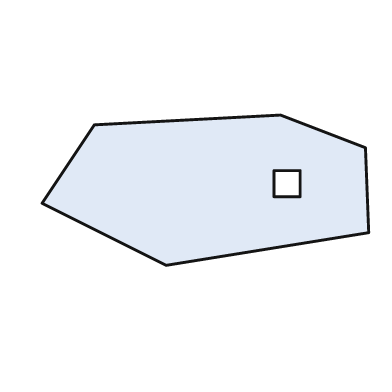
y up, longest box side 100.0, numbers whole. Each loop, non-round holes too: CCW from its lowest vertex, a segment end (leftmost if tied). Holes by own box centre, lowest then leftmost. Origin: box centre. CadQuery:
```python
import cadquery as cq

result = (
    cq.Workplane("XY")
    .moveTo(-12.0, -23.0)
    .lineTo(50.0, -13.0)
    .lineTo(49.0, 13.0)
    .lineTo(23.0, 23.0)
    .lineTo(-34.0, 20.0)
    .lineTo(-50.0, -4.0)
    .close()
    .moveTo(21.0, -2.0)
    .lineTo(29.0, -2.0)
    .lineTo(29.0, 6.0)
    .lineTo(21.0, 6.0)
    .close()
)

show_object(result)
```